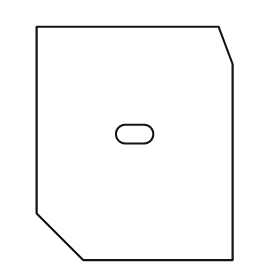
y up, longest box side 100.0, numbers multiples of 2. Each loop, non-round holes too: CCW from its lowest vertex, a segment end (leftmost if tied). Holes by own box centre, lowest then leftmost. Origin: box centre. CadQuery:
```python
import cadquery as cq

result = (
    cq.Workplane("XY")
    .moveTo(-22.0, -50.0)
    .lineTo(42.0, -50.0)
    .lineTo(42.0, 34.0)
    .lineTo(36.0, 50.0)
    .lineTo(-42.0, 50.0)
    .lineTo(-42.0, -30.0)
    .close()
    .moveTo(-4.0, 0.0)
    .lineTo(4.0, 0.0)
    .threePointArc((8.0, 4.0), (4.0, 8.0))
    .lineTo(-4.0, 8.0)
    .threePointArc((-8.0, 4.0), (-4.0, 0.0))
    .close()
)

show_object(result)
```